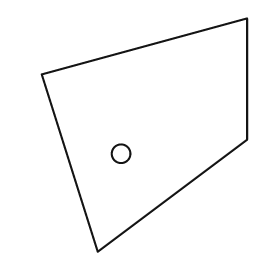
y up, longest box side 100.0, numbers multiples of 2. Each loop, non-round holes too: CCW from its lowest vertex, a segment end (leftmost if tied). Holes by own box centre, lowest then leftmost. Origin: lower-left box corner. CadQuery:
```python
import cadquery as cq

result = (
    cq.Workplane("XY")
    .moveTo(24.0, 0.0)
    .lineTo(88.0, 48.0)
    .lineTo(88.0, 100.0)
    .lineTo(0.0, 76.0)
    .close()
    .moveTo(34.0, 42.0)
    .circle(4.0)
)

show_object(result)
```